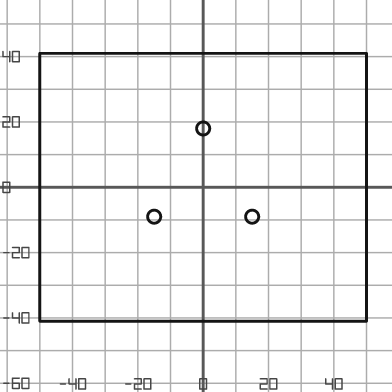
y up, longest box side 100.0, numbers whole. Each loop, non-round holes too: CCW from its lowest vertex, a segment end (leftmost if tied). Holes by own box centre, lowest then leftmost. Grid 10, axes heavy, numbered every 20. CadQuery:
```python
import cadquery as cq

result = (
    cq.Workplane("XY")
    .moveTo(-50.0, -41.0)
    .lineTo(50.0, -41.0)
    .lineTo(50.0, 41.0)
    .lineTo(-50.0, 41.0)
    .close()
    .moveTo(-15.0, -9.0)
    .circle(2.0)
    .moveTo(15.0, -9.0)
    .circle(2.0)
    .moveTo(0.0, 18.0)
    .circle(2.0)
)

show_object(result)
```